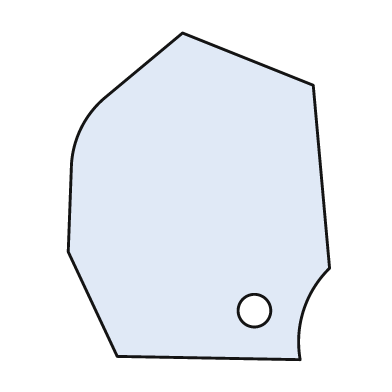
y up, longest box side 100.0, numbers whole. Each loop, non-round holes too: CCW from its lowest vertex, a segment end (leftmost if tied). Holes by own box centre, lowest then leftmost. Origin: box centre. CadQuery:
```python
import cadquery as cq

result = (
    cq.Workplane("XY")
    .moveTo(31.0, -50.0)
    .threePointArc((32.0, -35.0), (40.0, -22.0))
    .lineTo(35.0, 34.0)
    .lineTo(-5.0, 50.0)
    .lineTo(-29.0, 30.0)
    .threePointArc((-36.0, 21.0), (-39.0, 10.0))
    .lineTo(-40.0, -17.0)
    .lineTo(-25.0, -49.0)
    .close()
    .moveTo(17.0, -35.0)
    .circle(5.0)
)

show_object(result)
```